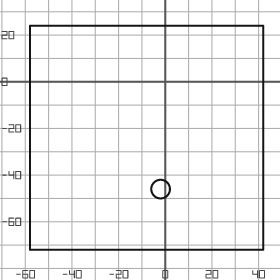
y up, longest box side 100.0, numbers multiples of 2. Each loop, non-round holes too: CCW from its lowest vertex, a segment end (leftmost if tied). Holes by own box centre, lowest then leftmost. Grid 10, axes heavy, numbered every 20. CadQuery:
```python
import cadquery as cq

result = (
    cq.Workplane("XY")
    .moveTo(-58.0, -72.0)
    .lineTo(42.0, -72.0)
    .lineTo(42.0, 24.0)
    .lineTo(-58.0, 24.0)
    .close()
    .moveTo(-2.0, -46.0)
    .circle(4.0)
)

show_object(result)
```